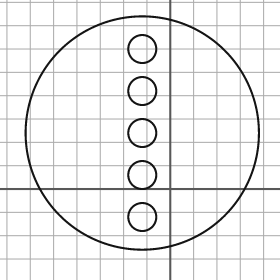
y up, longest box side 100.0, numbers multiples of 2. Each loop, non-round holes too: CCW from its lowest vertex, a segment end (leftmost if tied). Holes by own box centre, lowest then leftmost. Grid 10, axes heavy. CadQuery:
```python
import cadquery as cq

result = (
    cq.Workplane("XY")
    .moveTo(-12.0, 24.0)
    .circle(50.0)
    .moveTo(-12.0, -12.0)
    .circle(6.0)
    .moveTo(-12.0, 6.0)
    .circle(6.0)
    .moveTo(-12.0, 24.0)
    .circle(6.0)
    .moveTo(-12.0, 42.0)
    .circle(6.0)
    .moveTo(-12.0, 60.0)
    .circle(6.0)
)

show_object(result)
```